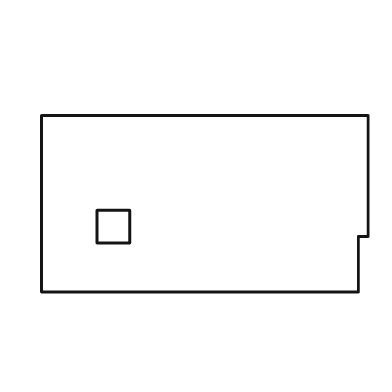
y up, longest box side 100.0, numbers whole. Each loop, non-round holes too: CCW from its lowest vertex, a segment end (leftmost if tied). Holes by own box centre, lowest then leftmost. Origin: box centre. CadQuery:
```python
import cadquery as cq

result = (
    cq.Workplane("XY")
    .moveTo(-50.0, -27.0)
    .lineTo(47.0, -27.0)
    .lineTo(47.0, -10.0)
    .lineTo(50.0, -10.0)
    .lineTo(50.0, 27.0)
    .lineTo(-50.0, 27.0)
    .close()
    .moveTo(-33.0, -12.0)
    .lineTo(-23.0, -12.0)
    .lineTo(-23.0, -2.0)
    .lineTo(-33.0, -2.0)
    .close()
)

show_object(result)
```